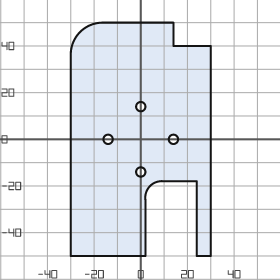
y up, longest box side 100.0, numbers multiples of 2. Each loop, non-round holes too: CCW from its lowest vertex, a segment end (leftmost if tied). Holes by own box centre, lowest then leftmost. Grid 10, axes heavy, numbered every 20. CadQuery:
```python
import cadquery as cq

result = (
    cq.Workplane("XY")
    .moveTo(-30.0, -50.0)
    .lineTo(2.0, -50.0)
    .lineTo(2.0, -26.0)
    .threePointArc((4.0, -20.0), (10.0, -18.0))
    .lineTo(24.0, -18.0)
    .lineTo(24.0, -50.0)
    .lineTo(30.0, -50.0)
    .lineTo(30.0, 40.0)
    .lineTo(14.0, 40.0)
    .lineTo(14.0, 50.0)
    .lineTo(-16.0, 50.0)
    .threePointArc((-26.0, 46.0), (-30.0, 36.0))
    .close()
    .moveTo(0.0, -14.0)
    .circle(2.0)
    .moveTo(-14.0, 0.0)
    .circle(2.0)
    .moveTo(14.0, 0.0)
    .circle(2.0)
    .moveTo(0.0, 14.0)
    .circle(2.0)
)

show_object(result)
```